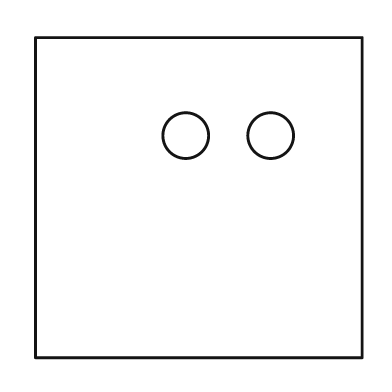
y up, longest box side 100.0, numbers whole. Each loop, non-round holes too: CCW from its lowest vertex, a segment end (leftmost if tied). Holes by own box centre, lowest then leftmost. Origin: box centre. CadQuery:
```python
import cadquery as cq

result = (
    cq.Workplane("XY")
    .moveTo(-50.0, -49.0)
    .lineTo(50.0, -49.0)
    .lineTo(50.0, 49.0)
    .lineTo(-50.0, 49.0)
    .close()
    .moveTo(-4.0, 19.0)
    .circle(7.0)
    .moveTo(22.0, 19.0)
    .circle(7.0)
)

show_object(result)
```